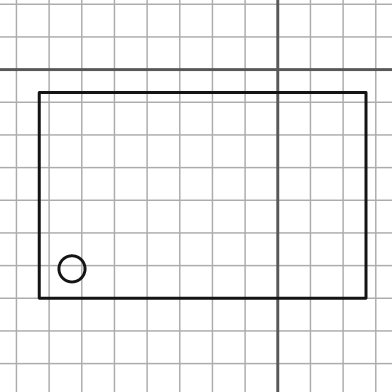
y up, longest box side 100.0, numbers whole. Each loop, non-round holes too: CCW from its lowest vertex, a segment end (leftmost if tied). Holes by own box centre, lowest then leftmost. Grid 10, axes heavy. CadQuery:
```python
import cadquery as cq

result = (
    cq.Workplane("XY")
    .moveTo(-73.0, -70.0)
    .lineTo(27.0, -70.0)
    .lineTo(27.0, -7.0)
    .lineTo(-73.0, -7.0)
    .close()
    .moveTo(-63.0, -61.0)
    .circle(4.0)
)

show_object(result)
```